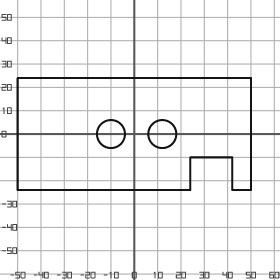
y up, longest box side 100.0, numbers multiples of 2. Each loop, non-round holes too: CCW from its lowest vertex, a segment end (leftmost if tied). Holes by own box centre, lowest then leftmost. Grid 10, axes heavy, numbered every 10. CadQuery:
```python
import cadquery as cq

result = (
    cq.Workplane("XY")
    .moveTo(-50.0, -24.0)
    .lineTo(24.0, -24.0)
    .lineTo(24.0, -10.0)
    .lineTo(42.0, -10.0)
    .lineTo(42.0, -24.0)
    .lineTo(50.0, -24.0)
    .lineTo(50.0, 24.0)
    .lineTo(-50.0, 24.0)
    .close()
    .moveTo(-10.0, 0.0)
    .circle(6.0)
    .moveTo(12.0, 0.0)
    .circle(6.0)
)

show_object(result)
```